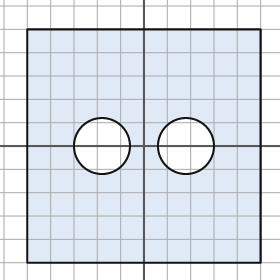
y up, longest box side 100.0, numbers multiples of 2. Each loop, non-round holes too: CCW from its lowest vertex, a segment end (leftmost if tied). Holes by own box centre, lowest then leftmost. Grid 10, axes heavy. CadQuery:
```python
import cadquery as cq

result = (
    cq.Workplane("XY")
    .moveTo(-50.0, -50.0)
    .lineTo(50.0, -50.0)
    .lineTo(50.0, 50.0)
    .lineTo(-50.0, 50.0)
    .close()
    .moveTo(-18.0, 0.0)
    .circle(12.0)
    .moveTo(18.0, 0.0)
    .circle(12.0)
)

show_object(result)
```